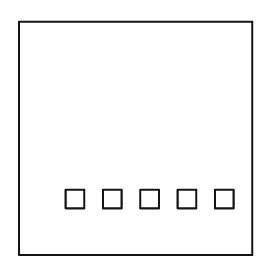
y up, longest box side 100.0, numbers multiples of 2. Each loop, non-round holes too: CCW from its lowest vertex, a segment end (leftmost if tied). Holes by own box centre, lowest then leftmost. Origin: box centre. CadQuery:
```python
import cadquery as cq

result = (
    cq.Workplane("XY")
    .moveTo(-50.0, -50.0)
    .lineTo(50.0, -50.0)
    .lineTo(50.0, 50.0)
    .lineTo(-50.0, 50.0)
    .close()
    .moveTo(-30.0, -30.0)
    .lineTo(-22.0, -30.0)
    .lineTo(-22.0, -22.0)
    .lineTo(-30.0, -22.0)
    .close()
    .moveTo(-14.0, -30.0)
    .lineTo(-6.0, -30.0)
    .lineTo(-6.0, -22.0)
    .lineTo(-14.0, -22.0)
    .close()
    .moveTo(2.0, -30.0)
    .lineTo(10.0, -30.0)
    .lineTo(10.0, -22.0)
    .lineTo(2.0, -22.0)
    .close()
    .moveTo(18.0, -30.0)
    .lineTo(26.0, -30.0)
    .lineTo(26.0, -22.0)
    .lineTo(18.0, -22.0)
    .close()
    .moveTo(34.0, -30.0)
    .lineTo(42.0, -30.0)
    .lineTo(42.0, -22.0)
    .lineTo(34.0, -22.0)
    .close()
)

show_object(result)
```